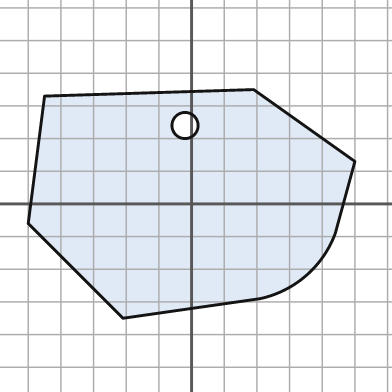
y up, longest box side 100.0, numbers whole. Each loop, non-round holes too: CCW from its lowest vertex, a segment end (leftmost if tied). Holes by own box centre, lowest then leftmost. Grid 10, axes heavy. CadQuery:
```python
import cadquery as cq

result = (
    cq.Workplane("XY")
    .moveTo(-21.0, -35.0)
    .lineTo(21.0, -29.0)
    .threePointArc((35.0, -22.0), (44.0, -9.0))
    .lineTo(50.0, 13.0)
    .lineTo(19.0, 35.0)
    .lineTo(-45.0, 33.0)
    .lineTo(-50.0, -6.0)
    .close()
    .moveTo(-2.0, 24.0)
    .circle(4.0)
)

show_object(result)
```